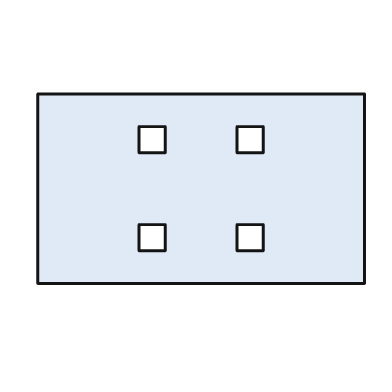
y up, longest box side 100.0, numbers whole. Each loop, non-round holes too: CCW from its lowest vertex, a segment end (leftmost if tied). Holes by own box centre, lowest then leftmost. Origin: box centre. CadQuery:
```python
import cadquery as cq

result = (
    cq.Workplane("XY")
    .moveTo(-50.0, -29.0)
    .lineTo(50.0, -29.0)
    .lineTo(50.0, 29.0)
    .lineTo(-50.0, 29.0)
    .close()
    .moveTo(-19.0, -19.0)
    .lineTo(-11.0, -19.0)
    .lineTo(-11.0, -11.0)
    .lineTo(-19.0, -11.0)
    .close()
    .moveTo(11.0, -19.0)
    .lineTo(19.0, -19.0)
    .lineTo(19.0, -11.0)
    .lineTo(11.0, -11.0)
    .close()
    .moveTo(-19.0, 11.0)
    .lineTo(-11.0, 11.0)
    .lineTo(-11.0, 19.0)
    .lineTo(-19.0, 19.0)
    .close()
    .moveTo(11.0, 11.0)
    .lineTo(19.0, 11.0)
    .lineTo(19.0, 19.0)
    .lineTo(11.0, 19.0)
    .close()
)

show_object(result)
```